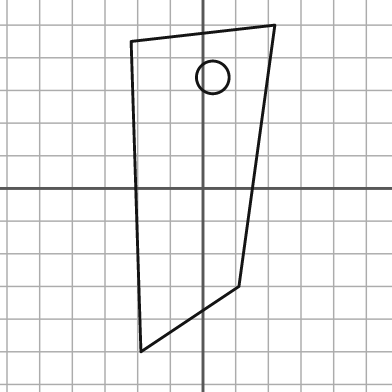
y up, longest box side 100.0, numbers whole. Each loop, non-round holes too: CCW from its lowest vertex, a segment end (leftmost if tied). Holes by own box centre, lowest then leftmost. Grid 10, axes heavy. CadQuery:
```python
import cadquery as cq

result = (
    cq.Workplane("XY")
    .moveTo(-19.0, -50.0)
    .lineTo(11.0, -30.0)
    .lineTo(22.0, 50.0)
    .lineTo(-22.0, 45.0)
    .close()
    .moveTo(3.0, 34.0)
    .circle(5.0)
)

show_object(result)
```